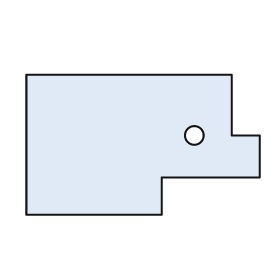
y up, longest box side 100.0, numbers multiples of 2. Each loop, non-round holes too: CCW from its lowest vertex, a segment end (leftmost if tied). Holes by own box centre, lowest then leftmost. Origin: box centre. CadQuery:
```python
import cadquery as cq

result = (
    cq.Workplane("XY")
    .moveTo(-50.0, -30.0)
    .lineTo(8.0, -30.0)
    .lineTo(8.0, -14.0)
    .lineTo(50.0, -14.0)
    .lineTo(50.0, 4.0)
    .lineTo(38.0, 4.0)
    .lineTo(38.0, 30.0)
    .lineTo(-50.0, 30.0)
    .close()
    .moveTo(22.0, 4.0)
    .circle(4.0)
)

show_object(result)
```